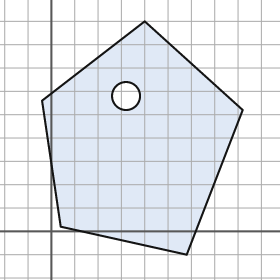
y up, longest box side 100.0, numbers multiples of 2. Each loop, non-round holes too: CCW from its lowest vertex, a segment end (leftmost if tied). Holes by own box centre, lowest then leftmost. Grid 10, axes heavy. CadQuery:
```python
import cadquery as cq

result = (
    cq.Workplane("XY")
    .moveTo(58.0, -10.0)
    .lineTo(82.0, 52.0)
    .lineTo(40.0, 90.0)
    .lineTo(-4.0, 56.0)
    .lineTo(4.0, 2.0)
    .close()
    .moveTo(32.0, 58.0)
    .circle(6.0)
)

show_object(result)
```